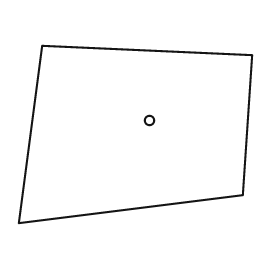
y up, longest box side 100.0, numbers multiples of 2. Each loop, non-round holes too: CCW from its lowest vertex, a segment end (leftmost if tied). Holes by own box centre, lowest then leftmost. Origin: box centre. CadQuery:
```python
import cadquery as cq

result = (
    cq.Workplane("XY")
    .moveTo(-50.0, -38.0)
    .lineTo(46.0, -26.0)
    .lineTo(50.0, 34.0)
    .lineTo(-40.0, 38.0)
    .close()
    .moveTo(6.0, 6.0)
    .circle(2.0)
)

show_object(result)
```